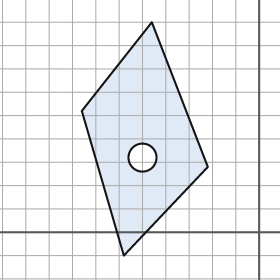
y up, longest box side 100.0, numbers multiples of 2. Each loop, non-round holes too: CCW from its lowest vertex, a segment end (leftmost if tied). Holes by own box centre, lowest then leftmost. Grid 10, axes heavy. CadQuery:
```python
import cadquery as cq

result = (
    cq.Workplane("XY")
    .moveTo(-58.0, -10.0)
    .lineTo(-22.0, 28.0)
    .lineTo(-46.0, 90.0)
    .lineTo(-76.0, 52.0)
    .close()
    .moveTo(-50.0, 32.0)
    .circle(6.0)
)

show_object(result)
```